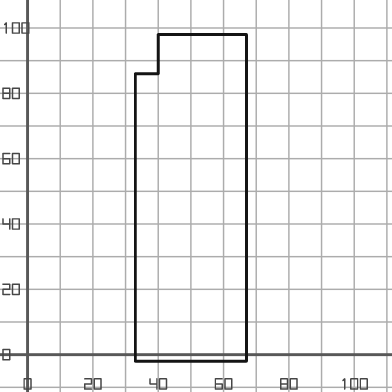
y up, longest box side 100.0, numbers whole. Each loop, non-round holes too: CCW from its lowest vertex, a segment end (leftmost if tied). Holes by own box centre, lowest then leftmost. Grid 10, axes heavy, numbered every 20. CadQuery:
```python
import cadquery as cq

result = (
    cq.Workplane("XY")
    .moveTo(33.0, -2.0)
    .lineTo(67.0, -2.0)
    .lineTo(67.0, 98.0)
    .lineTo(40.0, 98.0)
    .lineTo(40.0, 86.0)
    .lineTo(33.0, 86.0)
    .close()
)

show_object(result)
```